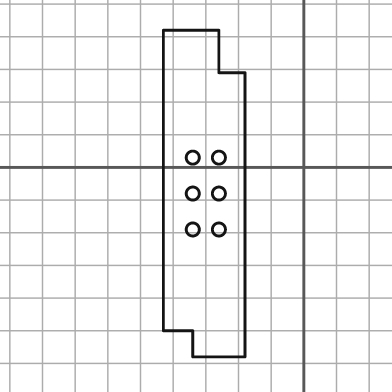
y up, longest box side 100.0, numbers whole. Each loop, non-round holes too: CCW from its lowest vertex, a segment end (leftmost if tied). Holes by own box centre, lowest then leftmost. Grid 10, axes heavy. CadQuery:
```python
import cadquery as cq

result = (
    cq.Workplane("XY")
    .moveTo(-34.0, -58.0)
    .lineTo(-18.0, -58.0)
    .lineTo(-18.0, 29.0)
    .lineTo(-26.0, 29.0)
    .lineTo(-26.0, 42.0)
    .lineTo(-43.0, 42.0)
    .lineTo(-43.0, -50.0)
    .lineTo(-34.0, -50.0)
    .close()
    .moveTo(-34.0, -19.0)
    .circle(2.0)
    .moveTo(-26.0, -19.0)
    .circle(2.0)
    .moveTo(-34.0, -8.0)
    .circle(2.0)
    .moveTo(-26.0, -8.0)
    .circle(2.0)
    .moveTo(-34.0, 3.0)
    .circle(2.0)
    .moveTo(-26.0, 3.0)
    .circle(2.0)
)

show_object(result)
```